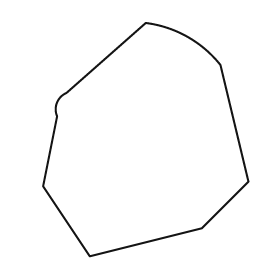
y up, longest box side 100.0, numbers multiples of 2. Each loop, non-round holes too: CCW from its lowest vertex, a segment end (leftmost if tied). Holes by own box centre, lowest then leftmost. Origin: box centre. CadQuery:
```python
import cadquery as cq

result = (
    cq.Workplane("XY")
    .moveTo(-24.0, -50.0)
    .lineTo(24.0, -38.0)
    .lineTo(44.0, -18.0)
    .lineTo(32.0, 32.0)
    .threePointArc((18.0, 44.0), (0.0, 50.0))
    .lineTo(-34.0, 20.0)
    .threePointArc((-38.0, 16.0), (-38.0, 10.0))
    .lineTo(-44.0, -20.0)
    .close()
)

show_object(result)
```